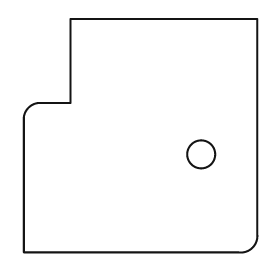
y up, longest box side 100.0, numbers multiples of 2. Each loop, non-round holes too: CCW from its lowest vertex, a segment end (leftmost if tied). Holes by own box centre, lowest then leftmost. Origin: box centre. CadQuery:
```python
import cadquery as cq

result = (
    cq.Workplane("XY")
    .moveTo(-50.0, -50.0)
    .lineTo(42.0, -50.0)
    .threePointArc((48.0, -48.0), (50.0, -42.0))
    .lineTo(50.0, 50.0)
    .lineTo(-30.0, 50.0)
    .lineTo(-30.0, 14.0)
    .lineTo(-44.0, 14.0)
    .threePointArc((-48.0, 12.0), (-50.0, 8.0))
    .close()
    .moveTo(26.0, -8.0)
    .circle(6.0)
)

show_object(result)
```